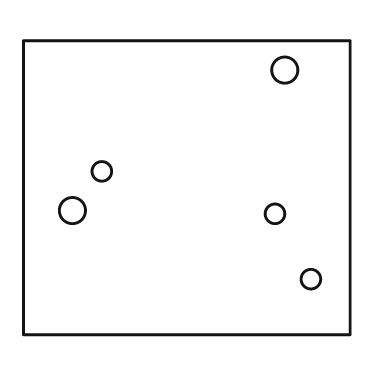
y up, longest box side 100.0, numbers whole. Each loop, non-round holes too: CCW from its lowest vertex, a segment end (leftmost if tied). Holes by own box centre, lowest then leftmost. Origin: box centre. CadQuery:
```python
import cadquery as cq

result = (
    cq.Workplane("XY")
    .moveTo(-50.0, -45.0)
    .lineTo(50.0, -45.0)
    .lineTo(50.0, 45.0)
    .lineTo(-50.0, 45.0)
    .close()
    .moveTo(38.0, -28.0)
    .circle(3.0)
    .moveTo(27.0, -8.0)
    .circle(3.0)
    .moveTo(-35.0, -7.0)
    .circle(4.0)
    .moveTo(-26.0, 5.0)
    .circle(3.0)
    .moveTo(30.0, 36.0)
    .circle(4.0)
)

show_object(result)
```